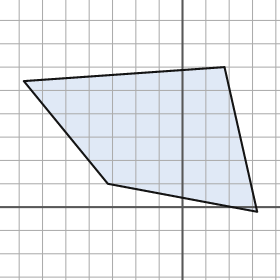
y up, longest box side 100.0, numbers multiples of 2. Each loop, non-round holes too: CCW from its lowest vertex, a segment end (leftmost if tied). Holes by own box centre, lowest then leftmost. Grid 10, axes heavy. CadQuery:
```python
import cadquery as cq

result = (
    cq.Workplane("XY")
    .moveTo(32.0, -2.0)
    .lineTo(18.0, 60.0)
    .lineTo(-68.0, 54.0)
    .lineTo(-32.0, 10.0)
    .close()
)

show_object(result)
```